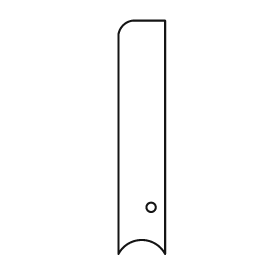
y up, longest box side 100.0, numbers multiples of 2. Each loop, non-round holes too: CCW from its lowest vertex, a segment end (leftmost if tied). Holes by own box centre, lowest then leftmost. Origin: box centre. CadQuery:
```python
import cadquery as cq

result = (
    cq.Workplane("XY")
    .moveTo(-10.0, -50.0)
    .threePointArc((0.0, -44.0), (10.0, -50.0))
    .lineTo(10.0, 50.0)
    .lineTo(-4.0, 50.0)
    .threePointArc((-8.0, 48.0), (-10.0, 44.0))
    .close()
    .moveTo(4.0, -30.0)
    .circle(2.0)
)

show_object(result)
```